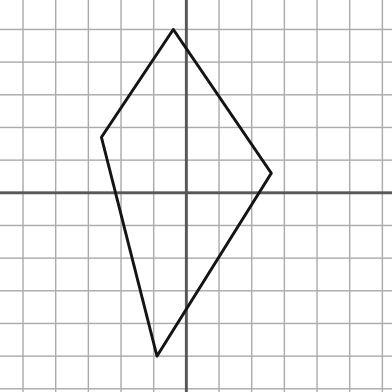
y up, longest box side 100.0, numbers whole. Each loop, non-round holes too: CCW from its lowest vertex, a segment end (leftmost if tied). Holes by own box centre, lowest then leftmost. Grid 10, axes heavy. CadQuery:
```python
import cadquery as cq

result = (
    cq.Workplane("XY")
    .moveTo(-9.0, -50.0)
    .lineTo(26.0, 6.0)
    .lineTo(-4.0, 50.0)
    .lineTo(-26.0, 17.0)
    .close()
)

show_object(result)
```